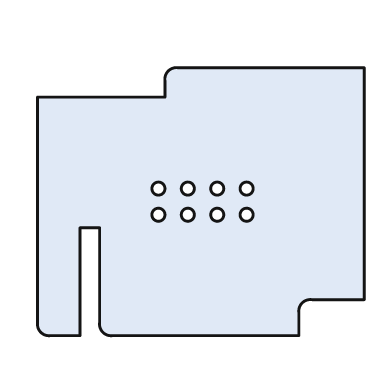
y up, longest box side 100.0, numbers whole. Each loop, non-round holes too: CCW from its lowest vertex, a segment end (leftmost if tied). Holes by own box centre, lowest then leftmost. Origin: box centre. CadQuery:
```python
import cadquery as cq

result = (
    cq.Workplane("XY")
    .moveTo(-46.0, -41.0)
    .lineTo(-37.0, -41.0)
    .lineTo(-37.0, -8.0)
    .lineTo(-31.0, -8.0)
    .lineTo(-31.0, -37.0)
    .threePointArc((-30.0, -40.0), (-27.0, -41.0))
    .lineTo(30.0, -41.0)
    .lineTo(30.0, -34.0)
    .threePointArc((31.0, -31.0), (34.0, -30.0))
    .lineTo(50.0, -30.0)
    .lineTo(50.0, 41.0)
    .lineTo(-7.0, 41.0)
    .threePointArc((-10.0, 40.0), (-11.0, 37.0))
    .lineTo(-11.0, 32.0)
    .lineTo(-50.0, 32.0)
    .lineTo(-50.0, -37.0)
    .threePointArc((-49.0, -40.0), (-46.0, -41.0))
    .close()
    .moveTo(-13.0, -4.0)
    .circle(2.0)
    .moveTo(-4.0, -4.0)
    .circle(2.0)
    .moveTo(5.0, -4.0)
    .circle(2.0)
    .moveTo(14.0, -4.0)
    .circle(2.0)
    .moveTo(-13.0, 4.0)
    .circle(2.0)
    .moveTo(-4.0, 4.0)
    .circle(2.0)
    .moveTo(5.0, 4.0)
    .circle(2.0)
    .moveTo(14.0, 4.0)
    .circle(2.0)
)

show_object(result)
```